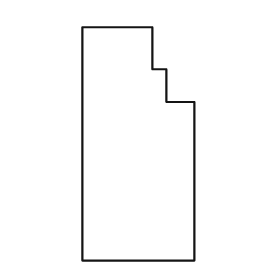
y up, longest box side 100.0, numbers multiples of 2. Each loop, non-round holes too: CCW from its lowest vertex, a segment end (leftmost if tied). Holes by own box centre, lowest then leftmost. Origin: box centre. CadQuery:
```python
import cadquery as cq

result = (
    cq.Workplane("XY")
    .moveTo(-24.0, -50.0)
    .lineTo(24.0, -50.0)
    .lineTo(24.0, 18.0)
    .lineTo(12.0, 18.0)
    .lineTo(12.0, 32.0)
    .lineTo(6.0, 32.0)
    .lineTo(6.0, 50.0)
    .lineTo(-24.0, 50.0)
    .close()
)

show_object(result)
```